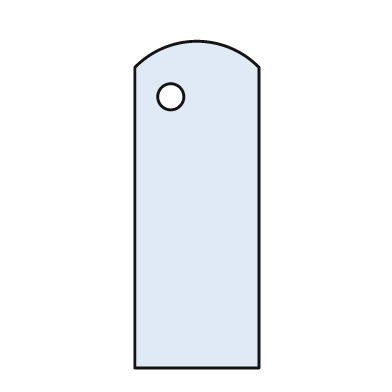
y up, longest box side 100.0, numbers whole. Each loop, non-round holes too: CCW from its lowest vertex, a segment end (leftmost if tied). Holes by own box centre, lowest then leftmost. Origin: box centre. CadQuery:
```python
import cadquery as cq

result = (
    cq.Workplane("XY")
    .moveTo(-19.0, -50.0)
    .lineTo(19.0, -50.0)
    .lineTo(19.0, 42.0)
    .threePointArc((0.0, 50.0), (-19.0, 42.0))
    .close()
    .moveTo(-8.0, 33.0)
    .circle(4.0)
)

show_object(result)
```